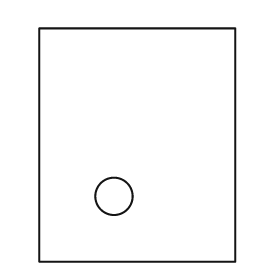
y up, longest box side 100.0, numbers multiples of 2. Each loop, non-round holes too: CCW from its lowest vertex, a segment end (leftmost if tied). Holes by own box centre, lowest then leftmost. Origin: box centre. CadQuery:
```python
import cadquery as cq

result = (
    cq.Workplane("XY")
    .moveTo(-42.0, -50.0)
    .lineTo(42.0, -50.0)
    .lineTo(42.0, 50.0)
    .lineTo(-42.0, 50.0)
    .close()
    .moveTo(-10.0, -22.0)
    .circle(8.0)
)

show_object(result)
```